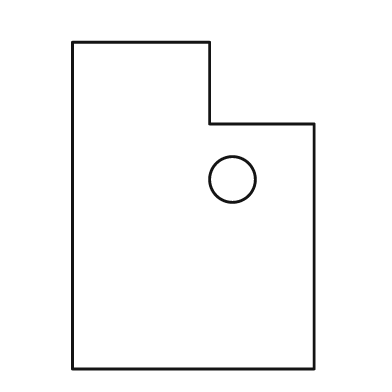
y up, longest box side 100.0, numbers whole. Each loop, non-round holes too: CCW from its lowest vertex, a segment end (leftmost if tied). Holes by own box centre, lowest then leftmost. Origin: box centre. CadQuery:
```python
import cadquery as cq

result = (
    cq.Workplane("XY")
    .moveTo(-37.0, -50.0)
    .lineTo(37.0, -50.0)
    .lineTo(37.0, 25.0)
    .lineTo(5.0, 25.0)
    .lineTo(5.0, 50.0)
    .lineTo(-37.0, 50.0)
    .close()
    .moveTo(12.0, 8.0)
    .circle(7.0)
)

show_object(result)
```